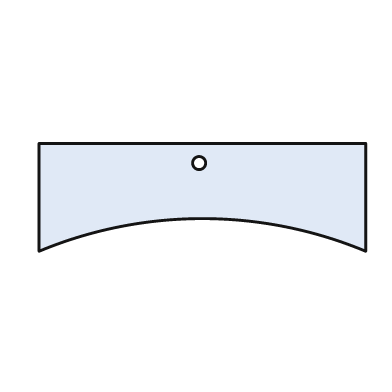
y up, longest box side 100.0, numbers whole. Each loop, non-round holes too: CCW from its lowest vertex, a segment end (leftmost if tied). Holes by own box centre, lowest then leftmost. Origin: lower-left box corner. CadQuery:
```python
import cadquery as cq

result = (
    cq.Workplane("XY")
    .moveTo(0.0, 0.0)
    .threePointArc((50.0, 10.0), (100.0, 0.0))
    .lineTo(100.0, 33.0)
    .lineTo(0.0, 33.0)
    .close()
    .moveTo(49.0, 27.0)
    .circle(2.0)
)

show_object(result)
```